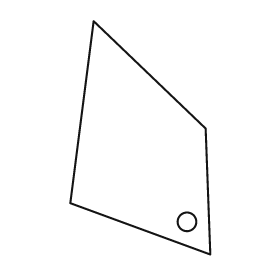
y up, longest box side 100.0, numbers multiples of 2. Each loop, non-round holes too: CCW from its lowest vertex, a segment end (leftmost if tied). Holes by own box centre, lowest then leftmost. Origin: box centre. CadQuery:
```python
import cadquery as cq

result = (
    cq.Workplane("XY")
    .moveTo(30.0, -50.0)
    .lineTo(28.0, 4.0)
    .lineTo(-20.0, 50.0)
    .lineTo(-30.0, -28.0)
    .close()
    .moveTo(20.0, -36.0)
    .circle(4.0)
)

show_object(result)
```